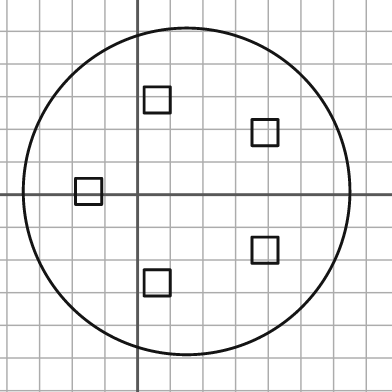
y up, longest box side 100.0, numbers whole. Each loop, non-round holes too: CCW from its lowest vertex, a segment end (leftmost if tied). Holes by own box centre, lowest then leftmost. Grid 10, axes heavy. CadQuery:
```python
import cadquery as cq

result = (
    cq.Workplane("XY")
    .moveTo(15.0, 1.0)
    .circle(50.0)
    .moveTo(2.0, -31.0)
    .lineTo(10.0, -31.0)
    .lineTo(10.0, -23.0)
    .lineTo(2.0, -23.0)
    .close()
    .moveTo(35.0, -21.0)
    .lineTo(43.0, -21.0)
    .lineTo(43.0, -13.0)
    .lineTo(35.0, -13.0)
    .close()
    .moveTo(-19.0, -3.0)
    .lineTo(-11.0, -3.0)
    .lineTo(-11.0, 5.0)
    .lineTo(-19.0, 5.0)
    .close()
    .moveTo(35.0, 15.0)
    .lineTo(43.0, 15.0)
    .lineTo(43.0, 23.0)
    .lineTo(35.0, 23.0)
    .close()
    .moveTo(2.0, 25.0)
    .lineTo(10.0, 25.0)
    .lineTo(10.0, 33.0)
    .lineTo(2.0, 33.0)
    .close()
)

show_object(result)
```